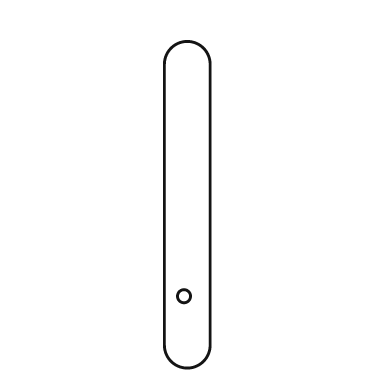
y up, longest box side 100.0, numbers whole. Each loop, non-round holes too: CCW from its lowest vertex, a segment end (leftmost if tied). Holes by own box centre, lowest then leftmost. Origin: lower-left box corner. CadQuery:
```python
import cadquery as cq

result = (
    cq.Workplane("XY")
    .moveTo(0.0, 7.0)
    .threePointArc((7.0, 0.0), (14.0, 7.0))
    .lineTo(14.0, 93.0)
    .threePointArc((7.0, 100.0), (0.0, 93.0))
    .close()
    .moveTo(6.0, 22.0)
    .circle(2.0)
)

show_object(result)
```